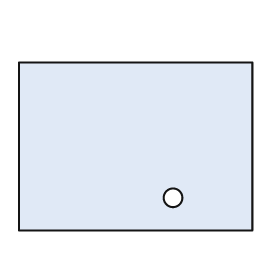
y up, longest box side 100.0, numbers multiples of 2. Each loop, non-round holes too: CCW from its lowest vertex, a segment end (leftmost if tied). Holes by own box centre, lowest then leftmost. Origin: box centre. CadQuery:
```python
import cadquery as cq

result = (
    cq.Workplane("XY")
    .moveTo(-50.0, -36.0)
    .lineTo(50.0, -36.0)
    .lineTo(50.0, 36.0)
    .lineTo(-50.0, 36.0)
    .close()
    .moveTo(16.0, -22.0)
    .circle(4.0)
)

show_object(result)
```